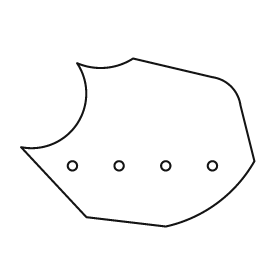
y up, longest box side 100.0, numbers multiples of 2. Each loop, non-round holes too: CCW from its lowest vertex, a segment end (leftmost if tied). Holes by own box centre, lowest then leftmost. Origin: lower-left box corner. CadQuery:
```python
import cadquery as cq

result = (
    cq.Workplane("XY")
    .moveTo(62.0, 0.0)
    .threePointArc((84.0, 10.0), (100.0, 28.0))
    .lineTo(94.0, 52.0)
    .threePointArc((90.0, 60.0), (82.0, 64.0))
    .lineTo(48.0, 72.0)
    .threePointArc((36.0, 68.0), (24.0, 70.0))
    .threePointArc((24.0, 44.0), (0.0, 34.0))
    .lineTo(28.0, 4.0)
    .close()
    .moveTo(22.0, 26.0)
    .circle(2.0)
    .moveTo(42.0, 26.0)
    .circle(2.0)
    .moveTo(62.0, 26.0)
    .circle(2.0)
    .moveTo(82.0, 26.0)
    .circle(2.0)
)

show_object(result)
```